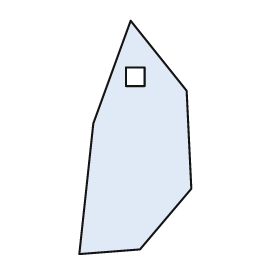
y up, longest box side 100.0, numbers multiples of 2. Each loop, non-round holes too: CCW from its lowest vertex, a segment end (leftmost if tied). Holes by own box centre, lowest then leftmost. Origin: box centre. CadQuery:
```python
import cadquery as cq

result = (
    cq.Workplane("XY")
    .moveTo(-24.0, -50.0)
    .lineTo(2.0, -48.0)
    .lineTo(24.0, -22.0)
    .lineTo(22.0, 20.0)
    .lineTo(-2.0, 50.0)
    .lineTo(-18.0, 6.0)
    .close()
    .moveTo(-4.0, 22.0)
    .lineTo(4.0, 22.0)
    .lineTo(4.0, 30.0)
    .lineTo(-4.0, 30.0)
    .close()
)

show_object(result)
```